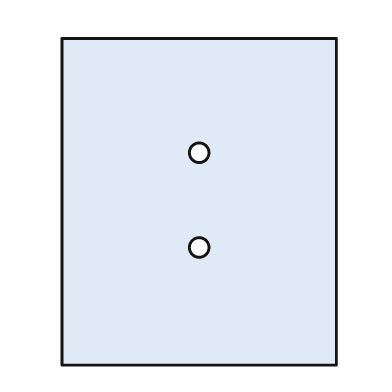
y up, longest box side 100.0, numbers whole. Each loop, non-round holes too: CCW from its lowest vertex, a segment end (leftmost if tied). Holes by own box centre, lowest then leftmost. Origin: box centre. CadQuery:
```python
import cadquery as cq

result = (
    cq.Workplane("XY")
    .moveTo(-42.0, -50.0)
    .lineTo(42.0, -50.0)
    .lineTo(42.0, 50.0)
    .lineTo(-42.0, 50.0)
    .close()
    .moveTo(0.0, -14.0)
    .circle(3.0)
    .moveTo(0.0, 15.0)
    .circle(3.0)
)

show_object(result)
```